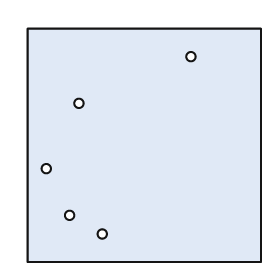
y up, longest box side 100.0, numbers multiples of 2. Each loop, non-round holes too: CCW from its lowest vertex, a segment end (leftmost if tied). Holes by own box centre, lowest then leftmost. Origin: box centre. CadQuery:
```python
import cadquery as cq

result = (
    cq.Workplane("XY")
    .moveTo(-50.0, -50.0)
    .lineTo(50.0, -50.0)
    .lineTo(50.0, 50.0)
    .lineTo(-50.0, 50.0)
    .close()
    .moveTo(-18.0, -38.0)
    .circle(2.0)
    .moveTo(-32.0, -30.0)
    .circle(2.0)
    .moveTo(-42.0, -10.0)
    .circle(2.0)
    .moveTo(-28.0, 18.0)
    .circle(2.0)
    .moveTo(20.0, 38.0)
    .circle(2.0)
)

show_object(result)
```